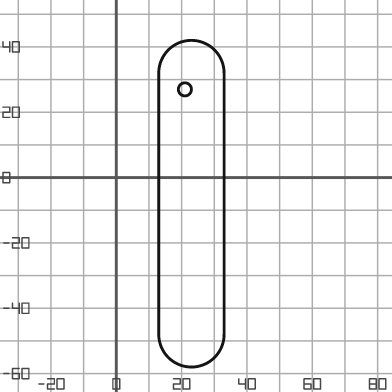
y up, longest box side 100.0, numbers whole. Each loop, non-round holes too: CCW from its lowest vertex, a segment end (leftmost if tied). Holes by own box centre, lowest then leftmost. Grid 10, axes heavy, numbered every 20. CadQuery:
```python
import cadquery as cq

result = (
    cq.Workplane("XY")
    .moveTo(13.0, -48.0)
    .threePointArc((23.0, -58.0), (33.0, -48.0))
    .lineTo(33.0, 32.0)
    .threePointArc((23.0, 42.0), (13.0, 32.0))
    .close()
    .moveTo(21.0, 27.0)
    .circle(2.0)
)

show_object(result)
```